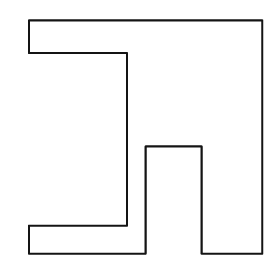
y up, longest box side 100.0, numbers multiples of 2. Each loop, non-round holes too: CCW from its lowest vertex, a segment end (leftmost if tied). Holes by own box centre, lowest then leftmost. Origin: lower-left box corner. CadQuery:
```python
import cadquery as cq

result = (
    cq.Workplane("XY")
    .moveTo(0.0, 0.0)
    .lineTo(50.0, 0.0)
    .lineTo(50.0, 46.0)
    .lineTo(74.0, 46.0)
    .lineTo(74.0, 0.0)
    .lineTo(100.0, 0.0)
    .lineTo(100.0, 100.0)
    .lineTo(0.0, 100.0)
    .lineTo(0.0, 86.0)
    .lineTo(42.0, 86.0)
    .lineTo(42.0, 12.0)
    .lineTo(0.0, 12.0)
    .close()
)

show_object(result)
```